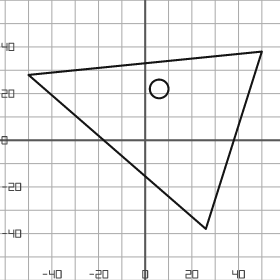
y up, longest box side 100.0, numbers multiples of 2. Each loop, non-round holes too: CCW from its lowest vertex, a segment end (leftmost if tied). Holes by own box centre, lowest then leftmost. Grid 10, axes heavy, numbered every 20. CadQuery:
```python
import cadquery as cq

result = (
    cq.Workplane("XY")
    .moveTo(26.0, -38.0)
    .lineTo(50.0, 38.0)
    .lineTo(-50.0, 28.0)
    .close()
    .moveTo(6.0, 22.0)
    .circle(4.0)
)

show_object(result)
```